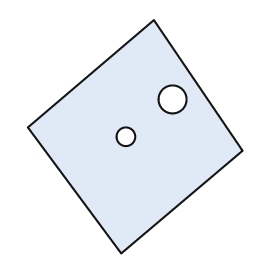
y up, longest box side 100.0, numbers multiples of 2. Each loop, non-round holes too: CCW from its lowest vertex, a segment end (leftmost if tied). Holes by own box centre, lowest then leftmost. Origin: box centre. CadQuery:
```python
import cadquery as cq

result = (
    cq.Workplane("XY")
    .moveTo(-6.0, -50.0)
    .lineTo(46.0, -6.0)
    .lineTo(8.0, 50.0)
    .lineTo(-46.0, 4.0)
    .close()
    .moveTo(-4.0, 0.0)
    .circle(4.0)
    .moveTo(16.0, 16.0)
    .circle(6.0)
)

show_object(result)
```